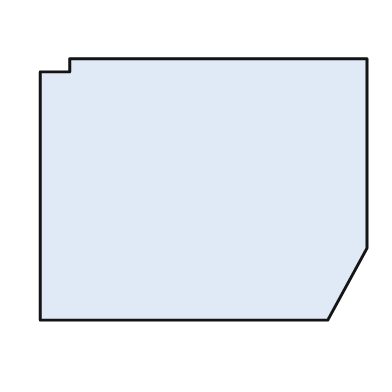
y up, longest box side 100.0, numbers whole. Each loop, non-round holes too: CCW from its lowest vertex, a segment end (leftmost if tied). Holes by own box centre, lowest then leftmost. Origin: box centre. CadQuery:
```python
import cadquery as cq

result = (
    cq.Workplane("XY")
    .moveTo(-50.0, -40.0)
    .lineTo(38.0, -40.0)
    .lineTo(50.0, -18.0)
    .lineTo(50.0, 40.0)
    .lineTo(-41.0, 40.0)
    .lineTo(-41.0, 36.0)
    .lineTo(-50.0, 36.0)
    .close()
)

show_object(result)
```